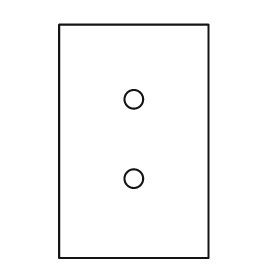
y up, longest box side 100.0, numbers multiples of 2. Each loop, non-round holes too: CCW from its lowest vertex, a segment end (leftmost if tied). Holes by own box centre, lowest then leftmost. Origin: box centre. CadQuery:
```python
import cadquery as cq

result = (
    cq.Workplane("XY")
    .moveTo(-32.0, -50.0)
    .lineTo(32.0, -50.0)
    .lineTo(32.0, 50.0)
    .lineTo(-32.0, 50.0)
    .close()
    .moveTo(0.0, -16.0)
    .circle(4.0)
    .moveTo(0.0, 18.0)
    .circle(4.0)
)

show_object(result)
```